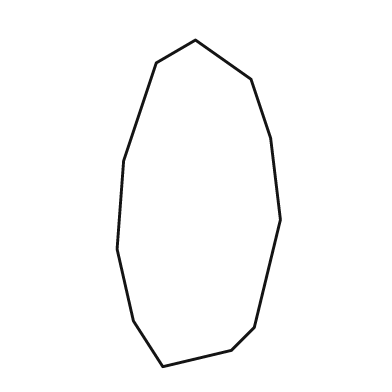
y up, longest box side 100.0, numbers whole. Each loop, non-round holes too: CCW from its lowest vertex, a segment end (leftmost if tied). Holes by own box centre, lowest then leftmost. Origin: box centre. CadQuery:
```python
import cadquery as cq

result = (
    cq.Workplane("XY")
    .moveTo(-11.0, -50.0)
    .lineTo(10.0, -45.0)
    .lineTo(17.0, -38.0)
    .lineTo(25.0, -5.0)
    .lineTo(22.0, 20.0)
    .lineTo(16.0, 38.0)
    .lineTo(-1.0, 50.0)
    .lineTo(-13.0, 43.0)
    .lineTo(-23.0, 13.0)
    .lineTo(-25.0, -14.0)
    .lineTo(-20.0, -36.0)
    .close()
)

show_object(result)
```